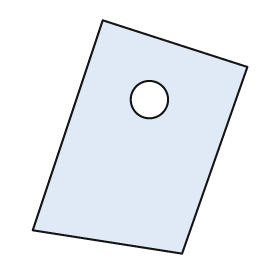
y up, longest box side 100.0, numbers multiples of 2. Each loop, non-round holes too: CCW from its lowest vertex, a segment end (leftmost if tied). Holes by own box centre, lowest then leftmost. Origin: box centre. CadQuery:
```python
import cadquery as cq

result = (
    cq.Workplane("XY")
    .moveTo(18.0, -50.0)
    .lineTo(46.0, 30.0)
    .lineTo(-16.0, 50.0)
    .lineTo(-46.0, -40.0)
    .close()
    .moveTo(4.0, 16.0)
    .circle(8.0)
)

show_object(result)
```